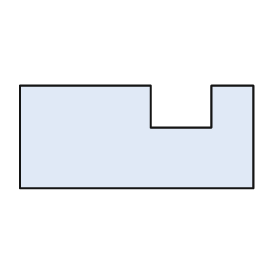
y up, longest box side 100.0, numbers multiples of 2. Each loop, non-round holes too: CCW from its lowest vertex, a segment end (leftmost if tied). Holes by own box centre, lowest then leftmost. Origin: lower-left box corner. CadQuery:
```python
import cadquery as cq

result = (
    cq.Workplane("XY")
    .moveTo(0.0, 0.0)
    .lineTo(100.0, 0.0)
    .lineTo(100.0, 44.0)
    .lineTo(82.0, 44.0)
    .lineTo(82.0, 26.0)
    .lineTo(56.0, 26.0)
    .lineTo(56.0, 44.0)
    .lineTo(0.0, 44.0)
    .close()
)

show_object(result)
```